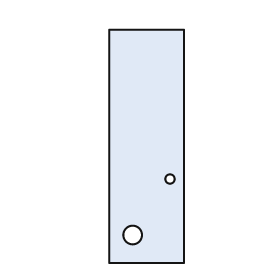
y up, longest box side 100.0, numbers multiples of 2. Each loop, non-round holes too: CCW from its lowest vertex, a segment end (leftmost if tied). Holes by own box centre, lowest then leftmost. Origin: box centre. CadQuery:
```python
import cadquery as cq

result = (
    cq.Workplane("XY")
    .moveTo(-16.0, -50.0)
    .lineTo(16.0, -50.0)
    .lineTo(16.0, 50.0)
    .lineTo(-16.0, 50.0)
    .close()
    .moveTo(-6.0, -38.0)
    .circle(4.0)
    .moveTo(10.0, -14.0)
    .circle(2.0)
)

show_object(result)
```